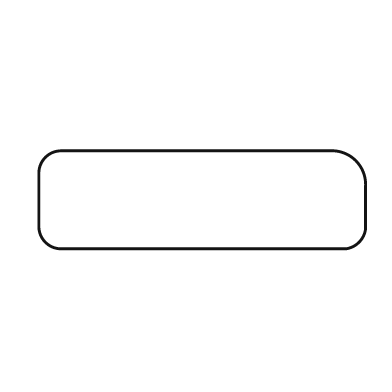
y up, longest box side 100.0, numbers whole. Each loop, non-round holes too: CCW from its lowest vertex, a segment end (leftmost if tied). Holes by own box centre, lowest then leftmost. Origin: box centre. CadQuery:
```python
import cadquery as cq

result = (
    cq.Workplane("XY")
    .moveTo(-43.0, -15.0)
    .lineTo(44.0, -15.0)
    .threePointArc((48.0, -13.0), (50.0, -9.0))
    .lineTo(50.0, 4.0)
    .threePointArc((47.0, 12.0), (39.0, 15.0))
    .lineTo(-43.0, 15.0)
    .threePointArc((-48.0, 13.0), (-50.0, 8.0))
    .lineTo(-50.0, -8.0)
    .threePointArc((-48.0, -13.0), (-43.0, -15.0))
    .close()
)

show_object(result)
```